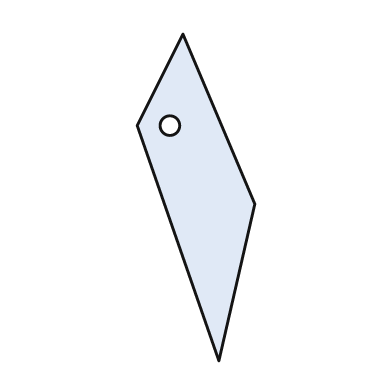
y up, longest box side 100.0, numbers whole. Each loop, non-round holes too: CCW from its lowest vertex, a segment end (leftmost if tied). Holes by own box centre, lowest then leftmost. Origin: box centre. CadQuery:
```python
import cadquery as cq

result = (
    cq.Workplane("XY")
    .moveTo(7.0, -50.0)
    .lineTo(18.0, -2.0)
    .lineTo(-4.0, 50.0)
    .lineTo(-18.0, 22.0)
    .close()
    .moveTo(-8.0, 22.0)
    .circle(3.0)
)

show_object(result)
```